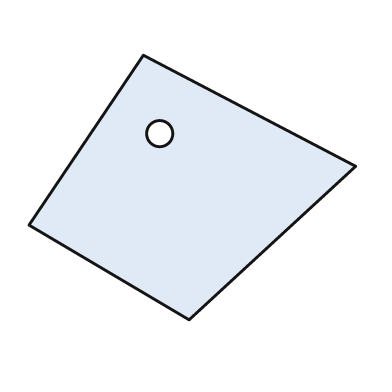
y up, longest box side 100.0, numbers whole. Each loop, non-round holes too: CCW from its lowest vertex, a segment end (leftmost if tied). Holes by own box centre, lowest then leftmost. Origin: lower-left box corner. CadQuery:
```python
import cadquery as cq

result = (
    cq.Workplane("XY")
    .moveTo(49.0, 0.0)
    .lineTo(100.0, 47.0)
    .lineTo(35.0, 81.0)
    .lineTo(0.0, 29.0)
    .close()
    .moveTo(40.0, 57.0)
    .circle(4.0)
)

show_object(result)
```